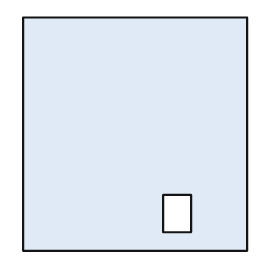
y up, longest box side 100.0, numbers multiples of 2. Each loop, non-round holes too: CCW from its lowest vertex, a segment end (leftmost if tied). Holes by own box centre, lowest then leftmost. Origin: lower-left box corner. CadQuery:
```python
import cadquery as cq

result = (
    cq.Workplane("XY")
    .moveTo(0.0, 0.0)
    .lineTo(96.0, 0.0)
    .lineTo(96.0, 100.0)
    .lineTo(0.0, 100.0)
    .close()
    .moveTo(60.0, 8.0)
    .lineTo(72.0, 8.0)
    .lineTo(72.0, 24.0)
    .lineTo(60.0, 24.0)
    .close()
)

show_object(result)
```